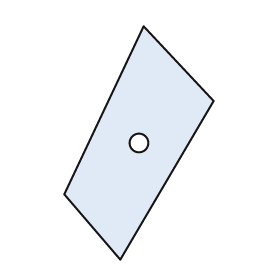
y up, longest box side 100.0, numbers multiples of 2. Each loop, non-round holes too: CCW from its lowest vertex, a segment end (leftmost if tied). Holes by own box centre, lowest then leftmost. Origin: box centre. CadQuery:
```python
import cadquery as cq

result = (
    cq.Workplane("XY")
    .moveTo(-8.0, -50.0)
    .lineTo(32.0, 18.0)
    .lineTo(2.0, 50.0)
    .lineTo(-32.0, -22.0)
    .close()
    .moveTo(0.0, 0.0)
    .circle(4.0)
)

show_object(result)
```